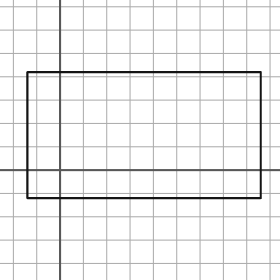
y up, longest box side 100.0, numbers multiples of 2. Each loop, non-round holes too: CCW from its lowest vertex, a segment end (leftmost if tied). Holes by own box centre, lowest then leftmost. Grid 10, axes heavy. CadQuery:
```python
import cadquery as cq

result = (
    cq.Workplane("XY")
    .moveTo(-14.0, -12.0)
    .lineTo(86.0, -12.0)
    .lineTo(86.0, 42.0)
    .lineTo(-14.0, 42.0)
    .close()
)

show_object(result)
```